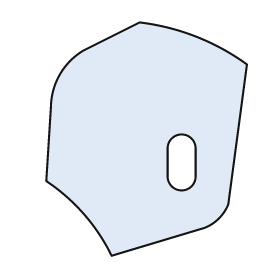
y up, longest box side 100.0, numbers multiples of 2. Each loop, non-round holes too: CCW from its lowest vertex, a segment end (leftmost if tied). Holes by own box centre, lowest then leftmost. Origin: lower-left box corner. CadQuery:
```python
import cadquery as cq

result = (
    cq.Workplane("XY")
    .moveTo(28.0, 0.0)
    .lineTo(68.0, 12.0)
    .threePointArc((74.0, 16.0), (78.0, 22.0))
    .lineTo(86.0, 82.0)
    .threePointArc((64.0, 94.0), (40.0, 100.0))
    .lineTo(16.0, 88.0)
    .threePointArc((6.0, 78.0), (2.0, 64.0))
    .lineTo(0.0, 32.0)
    .threePointArc((16.0, 18.0), (28.0, 0.0))
    .close()
    .moveTo(52.0, 34.0)
    .threePointArc((58.0, 28.0), (64.0, 34.0))
    .lineTo(64.0, 46.0)
    .threePointArc((58.0, 52.0), (52.0, 46.0))
    .close()
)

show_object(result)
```